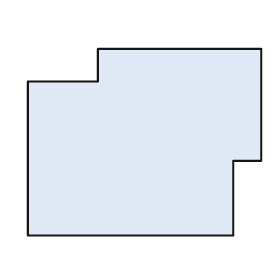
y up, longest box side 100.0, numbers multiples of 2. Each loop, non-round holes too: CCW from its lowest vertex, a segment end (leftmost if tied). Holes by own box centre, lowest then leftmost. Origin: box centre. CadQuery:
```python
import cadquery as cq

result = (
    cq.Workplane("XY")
    .moveTo(-50.0, -40.0)
    .lineTo(38.0, -40.0)
    .lineTo(38.0, -8.0)
    .lineTo(50.0, -8.0)
    .lineTo(50.0, 40.0)
    .lineTo(-20.0, 40.0)
    .lineTo(-20.0, 26.0)
    .lineTo(-50.0, 26.0)
    .close()
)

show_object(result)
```